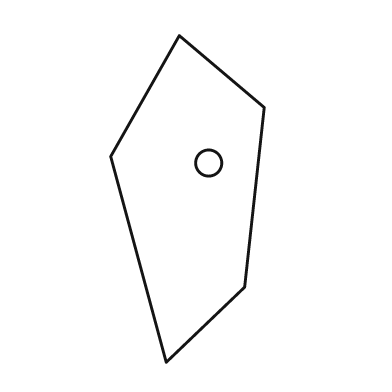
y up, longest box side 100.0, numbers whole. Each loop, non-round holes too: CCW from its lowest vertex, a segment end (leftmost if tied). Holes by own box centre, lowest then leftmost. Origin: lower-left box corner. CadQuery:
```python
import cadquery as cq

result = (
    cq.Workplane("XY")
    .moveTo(17.0, 0.0)
    .lineTo(41.0, 23.0)
    .lineTo(47.0, 78.0)
    .lineTo(21.0, 100.0)
    .lineTo(0.0, 63.0)
    .close()
    .moveTo(30.0, 61.0)
    .circle(4.0)
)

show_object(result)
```